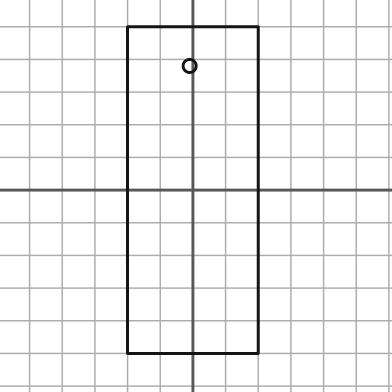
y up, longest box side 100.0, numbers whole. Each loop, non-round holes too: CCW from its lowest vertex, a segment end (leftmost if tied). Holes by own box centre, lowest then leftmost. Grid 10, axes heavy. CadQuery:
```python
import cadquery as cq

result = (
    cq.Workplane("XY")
    .moveTo(-20.0, -50.0)
    .lineTo(20.0, -50.0)
    .lineTo(20.0, 50.0)
    .lineTo(-20.0, 50.0)
    .close()
    .moveTo(-1.0, 38.0)
    .circle(2.0)
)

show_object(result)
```